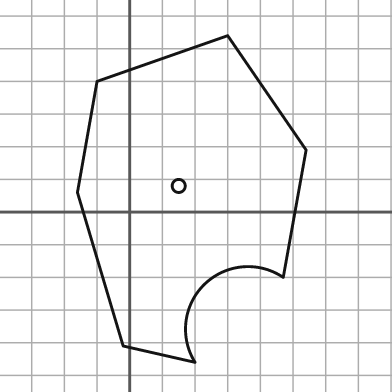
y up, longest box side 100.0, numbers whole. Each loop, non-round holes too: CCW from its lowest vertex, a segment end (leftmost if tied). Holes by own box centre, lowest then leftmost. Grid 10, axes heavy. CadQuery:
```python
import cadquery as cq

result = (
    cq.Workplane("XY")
    .moveTo(20.0, -46.0)
    .threePointArc((23.0, -22.0), (47.0, -20.0))
    .lineTo(54.0, 19.0)
    .lineTo(30.0, 54.0)
    .lineTo(-10.0, 40.0)
    .lineTo(-16.0, 6.0)
    .lineTo(-2.0, -41.0)
    .close()
    .moveTo(15.0, 8.0)
    .circle(2.0)
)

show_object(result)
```